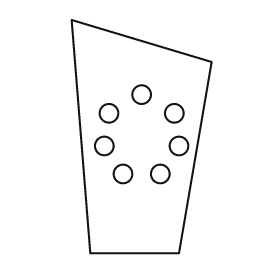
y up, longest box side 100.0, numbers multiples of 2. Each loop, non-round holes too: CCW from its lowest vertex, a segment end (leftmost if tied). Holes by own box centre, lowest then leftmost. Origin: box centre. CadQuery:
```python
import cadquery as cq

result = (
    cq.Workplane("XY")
    .moveTo(-22.0, -50.0)
    .lineTo(16.0, -50.0)
    .lineTo(30.0, 32.0)
    .lineTo(-30.0, 50.0)
    .close()
    .moveTo(-8.0, -16.0)
    .circle(4.0)
    .moveTo(8.0, -16.0)
    .circle(4.0)
    .moveTo(-16.0, -4.0)
    .circle(4.0)
    .moveTo(16.0, -4.0)
    .circle(4.0)
    .moveTo(-14.0, 10.0)
    .circle(4.0)
    .moveTo(14.0, 10.0)
    .circle(4.0)
    .moveTo(0.0, 18.0)
    .circle(4.0)
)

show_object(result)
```